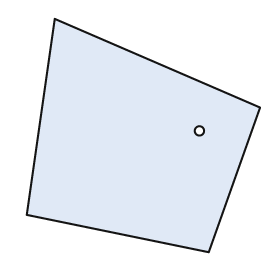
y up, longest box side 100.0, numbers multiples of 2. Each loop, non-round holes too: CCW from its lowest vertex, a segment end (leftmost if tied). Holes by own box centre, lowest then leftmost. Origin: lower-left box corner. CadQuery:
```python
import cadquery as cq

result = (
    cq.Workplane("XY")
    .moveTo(78.0, 0.0)
    .lineTo(100.0, 62.0)
    .lineTo(12.0, 100.0)
    .lineTo(0.0, 16.0)
    .close()
    .moveTo(74.0, 52.0)
    .circle(2.0)
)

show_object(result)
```